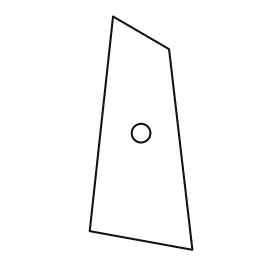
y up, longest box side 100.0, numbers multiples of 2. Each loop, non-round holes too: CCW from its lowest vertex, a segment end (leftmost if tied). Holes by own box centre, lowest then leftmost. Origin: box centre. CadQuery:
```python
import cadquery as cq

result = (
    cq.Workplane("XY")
    .moveTo(22.0, -50.0)
    .lineTo(12.0, 36.0)
    .lineTo(-12.0, 50.0)
    .lineTo(-22.0, -42.0)
    .close()
    .moveTo(0.0, 0.0)
    .circle(4.0)
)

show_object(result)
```